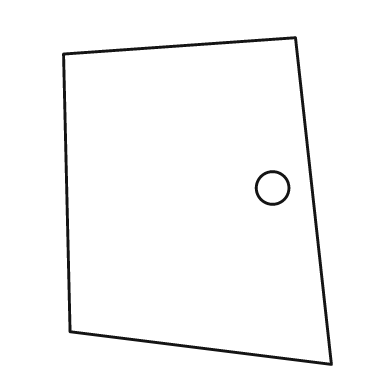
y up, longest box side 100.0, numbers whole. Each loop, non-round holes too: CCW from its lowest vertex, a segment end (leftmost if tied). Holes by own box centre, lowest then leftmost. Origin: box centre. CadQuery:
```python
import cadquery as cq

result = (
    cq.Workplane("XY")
    .moveTo(41.0, -50.0)
    .lineTo(30.0, 50.0)
    .lineTo(-41.0, 45.0)
    .lineTo(-39.0, -40.0)
    .close()
    .moveTo(23.0, 4.0)
    .circle(5.0)
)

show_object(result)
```